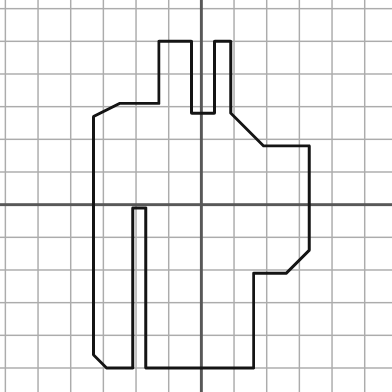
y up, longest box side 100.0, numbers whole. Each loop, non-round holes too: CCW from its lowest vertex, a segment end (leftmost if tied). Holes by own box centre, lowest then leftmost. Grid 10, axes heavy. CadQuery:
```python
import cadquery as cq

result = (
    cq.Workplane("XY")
    .moveTo(-29.0, -50.0)
    .lineTo(-21.0, -50.0)
    .lineTo(-21.0, -1.0)
    .lineTo(-17.0, -1.0)
    .lineTo(-17.0, -50.0)
    .lineTo(16.0, -50.0)
    .lineTo(16.0, -21.0)
    .lineTo(26.0, -21.0)
    .lineTo(33.0, -14.0)
    .lineTo(33.0, 18.0)
    .lineTo(19.0, 18.0)
    .lineTo(9.0, 28.0)
    .lineTo(9.0, 50.0)
    .lineTo(4.0, 50.0)
    .lineTo(4.0, 28.0)
    .lineTo(-3.0, 28.0)
    .lineTo(-3.0, 50.0)
    .lineTo(-13.0, 50.0)
    .lineTo(-13.0, 31.0)
    .lineTo(-25.0, 31.0)
    .lineTo(-33.0, 27.0)
    .lineTo(-33.0, -46.0)
    .close()
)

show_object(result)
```